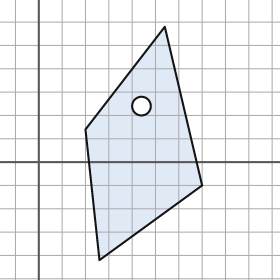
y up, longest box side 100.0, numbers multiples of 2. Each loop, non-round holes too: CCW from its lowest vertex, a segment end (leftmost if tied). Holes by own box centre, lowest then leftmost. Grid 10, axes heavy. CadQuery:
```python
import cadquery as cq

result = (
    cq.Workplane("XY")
    .moveTo(26.0, -42.0)
    .lineTo(70.0, -10.0)
    .lineTo(54.0, 58.0)
    .lineTo(20.0, 14.0)
    .close()
    .moveTo(44.0, 24.0)
    .circle(4.0)
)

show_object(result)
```